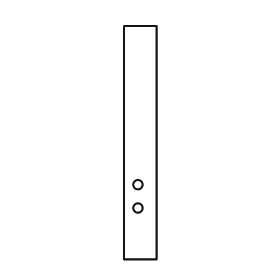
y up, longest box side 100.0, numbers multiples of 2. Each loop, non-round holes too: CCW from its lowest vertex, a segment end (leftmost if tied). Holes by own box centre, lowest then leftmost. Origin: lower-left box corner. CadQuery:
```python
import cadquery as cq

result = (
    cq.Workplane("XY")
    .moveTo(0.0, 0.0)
    .lineTo(14.0, 0.0)
    .lineTo(14.0, 100.0)
    .lineTo(0.0, 100.0)
    .close()
    .moveTo(6.0, 22.0)
    .circle(2.0)
    .moveTo(6.0, 32.0)
    .circle(2.0)
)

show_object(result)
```